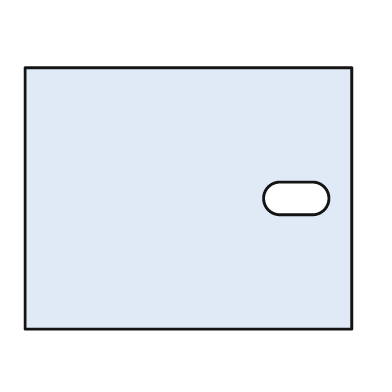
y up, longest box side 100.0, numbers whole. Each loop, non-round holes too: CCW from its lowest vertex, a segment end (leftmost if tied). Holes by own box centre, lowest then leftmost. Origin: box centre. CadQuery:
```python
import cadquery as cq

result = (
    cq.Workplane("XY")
    .moveTo(-50.0, -40.0)
    .lineTo(50.0, -40.0)
    .lineTo(50.0, 40.0)
    .lineTo(-50.0, 40.0)
    .close()
    .moveTo(28.0, -5.0)
    .lineTo(38.0, -5.0)
    .threePointArc((43.0, 0.0), (38.0, 5.0))
    .lineTo(28.0, 5.0)
    .threePointArc((23.0, 0.0), (28.0, -5.0))
    .close()
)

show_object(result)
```